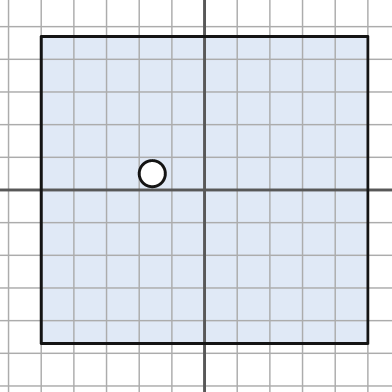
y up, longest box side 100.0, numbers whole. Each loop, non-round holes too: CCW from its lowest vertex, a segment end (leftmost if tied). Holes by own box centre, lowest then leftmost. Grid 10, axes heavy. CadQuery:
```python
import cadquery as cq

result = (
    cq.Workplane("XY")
    .moveTo(-50.0, -47.0)
    .lineTo(50.0, -47.0)
    .lineTo(50.0, 47.0)
    .lineTo(-50.0, 47.0)
    .close()
    .moveTo(-16.0, 5.0)
    .circle(4.0)
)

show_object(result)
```